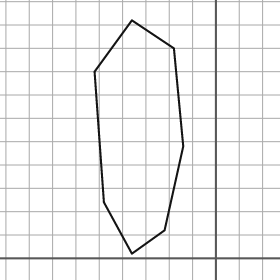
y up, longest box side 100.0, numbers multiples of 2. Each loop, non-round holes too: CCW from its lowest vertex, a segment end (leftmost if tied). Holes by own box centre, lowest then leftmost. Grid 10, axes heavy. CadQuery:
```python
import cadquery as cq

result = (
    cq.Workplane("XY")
    .moveTo(-36.0, 2.0)
    .lineTo(-22.0, 12.0)
    .lineTo(-14.0, 48.0)
    .lineTo(-18.0, 90.0)
    .lineTo(-36.0, 102.0)
    .lineTo(-52.0, 80.0)
    .lineTo(-48.0, 24.0)
    .close()
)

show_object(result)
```